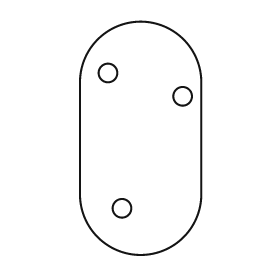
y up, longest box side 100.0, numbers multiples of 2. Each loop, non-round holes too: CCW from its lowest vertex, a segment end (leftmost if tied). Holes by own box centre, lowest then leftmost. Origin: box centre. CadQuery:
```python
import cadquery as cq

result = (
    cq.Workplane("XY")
    .moveTo(-26.0, -24.0)
    .threePointArc((0.0, -50.0), (26.0, -24.0))
    .lineTo(26.0, 24.0)
    .threePointArc((0.0, 50.0), (-26.0, 24.0))
    .close()
    .moveTo(-8.0, -30.0)
    .circle(4.0)
    .moveTo(18.0, 18.0)
    .circle(4.0)
    .moveTo(-14.0, 28.0)
    .circle(4.0)
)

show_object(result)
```